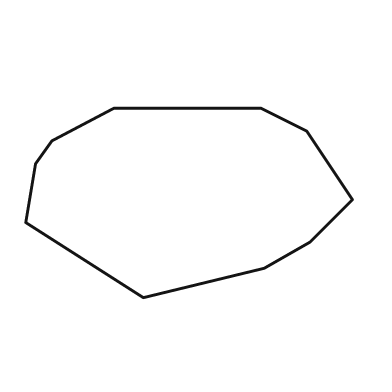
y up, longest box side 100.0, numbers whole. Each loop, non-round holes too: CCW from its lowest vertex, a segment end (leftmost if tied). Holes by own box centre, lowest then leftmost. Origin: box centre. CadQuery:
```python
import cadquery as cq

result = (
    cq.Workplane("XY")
    .moveTo(-14.0, -29.0)
    .lineTo(23.0, -20.0)
    .lineTo(37.0, -12.0)
    .lineTo(50.0, 1.0)
    .lineTo(36.0, 22.0)
    .lineTo(22.0, 29.0)
    .lineTo(-23.0, 29.0)
    .lineTo(-42.0, 19.0)
    .lineTo(-47.0, 12.0)
    .lineTo(-50.0, -6.0)
    .close()
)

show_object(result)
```